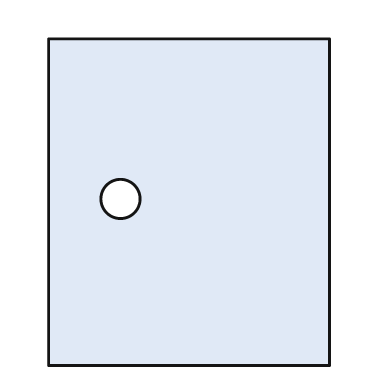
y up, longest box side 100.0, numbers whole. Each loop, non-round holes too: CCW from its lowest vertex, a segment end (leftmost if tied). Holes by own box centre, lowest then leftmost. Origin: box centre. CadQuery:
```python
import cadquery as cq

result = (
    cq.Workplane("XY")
    .moveTo(-43.0, -50.0)
    .lineTo(43.0, -50.0)
    .lineTo(43.0, 50.0)
    .lineTo(-43.0, 50.0)
    .close()
    .moveTo(-21.0, 1.0)
    .circle(6.0)
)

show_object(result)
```